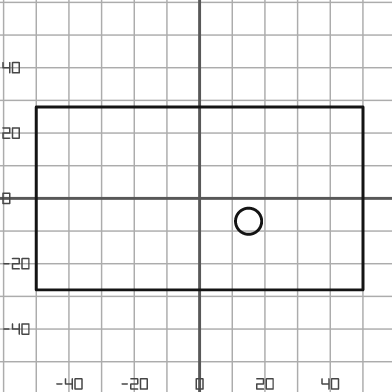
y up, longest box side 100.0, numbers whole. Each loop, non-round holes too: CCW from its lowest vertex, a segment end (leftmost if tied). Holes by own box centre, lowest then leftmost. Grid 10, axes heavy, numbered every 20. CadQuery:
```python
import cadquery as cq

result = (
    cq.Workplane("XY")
    .moveTo(-50.0, -28.0)
    .lineTo(50.0, -28.0)
    .lineTo(50.0, 28.0)
    .lineTo(-50.0, 28.0)
    .close()
    .moveTo(15.0, -7.0)
    .circle(4.0)
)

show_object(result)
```